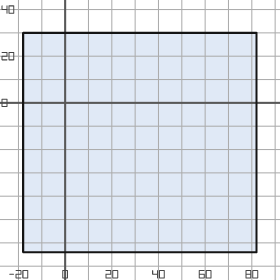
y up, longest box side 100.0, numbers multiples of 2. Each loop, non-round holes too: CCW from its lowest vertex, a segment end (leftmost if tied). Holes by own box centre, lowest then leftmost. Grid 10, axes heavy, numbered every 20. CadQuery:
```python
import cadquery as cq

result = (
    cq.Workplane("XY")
    .moveTo(-18.0, -64.0)
    .lineTo(82.0, -64.0)
    .lineTo(82.0, 30.0)
    .lineTo(-18.0, 30.0)
    .close()
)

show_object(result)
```